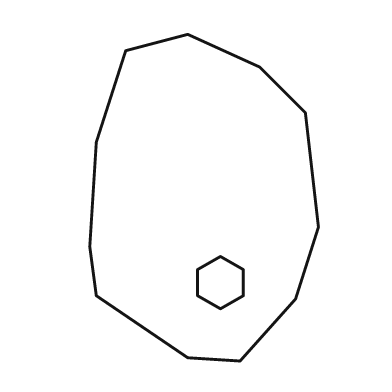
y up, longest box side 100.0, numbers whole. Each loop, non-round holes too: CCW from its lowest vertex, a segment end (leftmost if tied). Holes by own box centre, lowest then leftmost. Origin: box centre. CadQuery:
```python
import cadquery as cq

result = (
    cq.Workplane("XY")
    .moveTo(11.0, -50.0)
    .lineTo(28.0, -31.0)
    .lineTo(35.0, -9.0)
    .lineTo(31.0, 26.0)
    .lineTo(17.0, 40.0)
    .lineTo(-5.0, 50.0)
    .lineTo(-24.0, 45.0)
    .lineTo(-33.0, 17.0)
    .lineTo(-35.0, -15.0)
    .lineTo(-33.0, -30.0)
    .lineTo(-5.0, -49.0)
    .close()
    .moveTo(5.0, -34.0)
    .lineTo(12.0, -30.0)
    .lineTo(12.0, -22.0)
    .lineTo(5.0, -18.0)
    .lineTo(-2.0, -22.0)
    .lineTo(-2.0, -30.0)
    .close()
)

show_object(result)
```